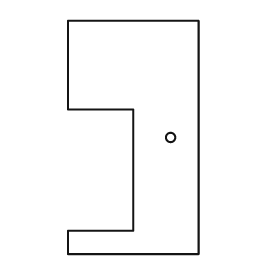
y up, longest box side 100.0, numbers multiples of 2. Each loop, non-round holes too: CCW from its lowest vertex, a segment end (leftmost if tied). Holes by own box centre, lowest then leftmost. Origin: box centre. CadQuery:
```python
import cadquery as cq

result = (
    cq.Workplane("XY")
    .moveTo(-28.0, -50.0)
    .lineTo(28.0, -50.0)
    .lineTo(28.0, 50.0)
    .lineTo(-28.0, 50.0)
    .lineTo(-28.0, 12.0)
    .lineTo(0.0, 12.0)
    .lineTo(0.0, -40.0)
    .lineTo(-28.0, -40.0)
    .close()
    .moveTo(16.0, 0.0)
    .circle(2.0)
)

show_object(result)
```